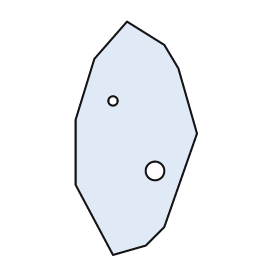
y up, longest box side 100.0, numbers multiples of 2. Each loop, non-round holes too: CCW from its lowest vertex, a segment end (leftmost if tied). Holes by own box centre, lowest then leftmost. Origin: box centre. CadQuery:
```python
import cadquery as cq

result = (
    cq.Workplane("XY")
    .moveTo(-10.0, -50.0)
    .lineTo(4.0, -46.0)
    .lineTo(12.0, -38.0)
    .lineTo(26.0, 2.0)
    .lineTo(18.0, 30.0)
    .lineTo(12.0, 40.0)
    .lineTo(-4.0, 50.0)
    .lineTo(-18.0, 34.0)
    .lineTo(-26.0, 8.0)
    .lineTo(-26.0, -20.0)
    .close()
    .moveTo(8.0, -14.0)
    .circle(4.0)
    .moveTo(-10.0, 16.0)
    .circle(2.0)
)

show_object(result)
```